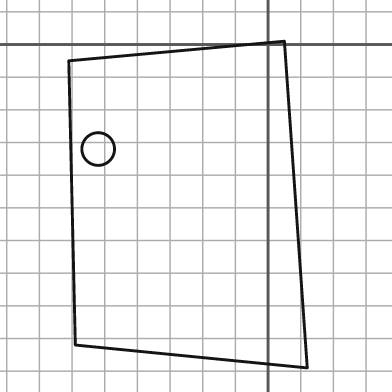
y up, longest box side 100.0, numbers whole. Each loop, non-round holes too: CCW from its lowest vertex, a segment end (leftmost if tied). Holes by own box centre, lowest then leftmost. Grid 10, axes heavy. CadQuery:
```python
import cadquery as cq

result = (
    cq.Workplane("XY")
    .moveTo(12.0, -99.0)
    .lineTo(5.0, 1.0)
    .lineTo(-61.0, -5.0)
    .lineTo(-59.0, -92.0)
    .close()
    .moveTo(-52.0, -32.0)
    .circle(5.0)
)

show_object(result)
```